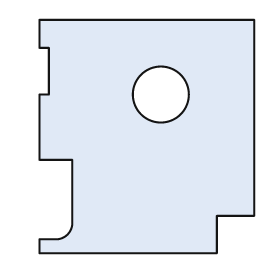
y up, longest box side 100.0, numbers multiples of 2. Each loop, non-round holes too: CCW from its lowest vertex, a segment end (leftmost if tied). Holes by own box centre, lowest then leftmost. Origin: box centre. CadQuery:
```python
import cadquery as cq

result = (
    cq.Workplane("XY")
    .moveTo(-46.0, -50.0)
    .lineTo(30.0, -50.0)
    .lineTo(30.0, -34.0)
    .lineTo(46.0, -34.0)
    .lineTo(46.0, 50.0)
    .lineTo(-46.0, 50.0)
    .lineTo(-46.0, 38.0)
    .lineTo(-42.0, 38.0)
    .lineTo(-42.0, 18.0)
    .lineTo(-46.0, 18.0)
    .lineTo(-46.0, -10.0)
    .lineTo(-32.0, -10.0)
    .lineTo(-32.0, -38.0)
    .threePointArc((-34.0, -42.0), (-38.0, -44.0))
    .lineTo(-46.0, -44.0)
    .close()
    .moveTo(6.0, 18.0)
    .circle(12.0)
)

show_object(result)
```